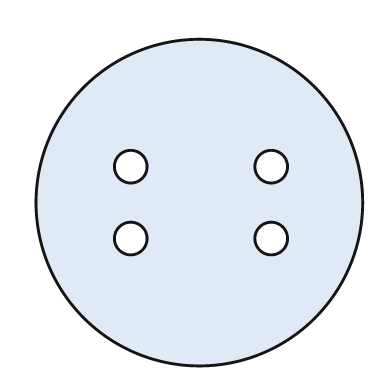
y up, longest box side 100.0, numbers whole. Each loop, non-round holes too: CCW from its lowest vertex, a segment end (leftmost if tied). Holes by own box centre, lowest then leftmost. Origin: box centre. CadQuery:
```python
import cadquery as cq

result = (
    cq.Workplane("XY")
    .moveTo(0.0, 0.0)
    .circle(50.0)
    .moveTo(-21.0, -11.0)
    .circle(5.0)
    .moveTo(22.0, -11.0)
    .circle(5.0)
    .moveTo(-21.0, 11.0)
    .circle(5.0)
    .moveTo(22.0, 11.0)
    .circle(5.0)
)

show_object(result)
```